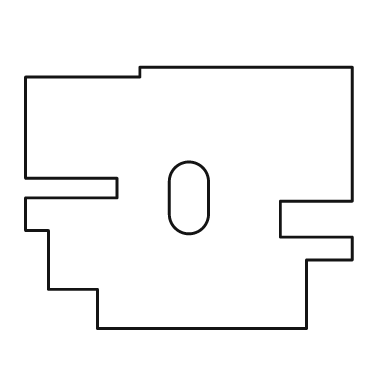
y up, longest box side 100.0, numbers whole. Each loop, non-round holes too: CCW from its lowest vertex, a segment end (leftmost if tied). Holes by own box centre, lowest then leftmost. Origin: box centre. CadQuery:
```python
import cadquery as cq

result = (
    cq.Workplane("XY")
    .moveTo(-28.0, -40.0)
    .lineTo(36.0, -40.0)
    .lineTo(36.0, -19.0)
    .lineTo(50.0, -19.0)
    .lineTo(50.0, -12.0)
    .lineTo(28.0, -12.0)
    .lineTo(28.0, -1.0)
    .lineTo(50.0, -1.0)
    .lineTo(50.0, 40.0)
    .lineTo(-15.0, 40.0)
    .lineTo(-15.0, 37.0)
    .lineTo(-50.0, 37.0)
    .lineTo(-50.0, 6.0)
    .lineTo(-22.0, 6.0)
    .lineTo(-22.0, 0.0)
    .lineTo(-50.0, 0.0)
    .lineTo(-50.0, -10.0)
    .lineTo(-43.0, -10.0)
    .lineTo(-43.0, -28.0)
    .lineTo(-28.0, -28.0)
    .close()
    .moveTo(-6.0, -5.0)
    .threePointArc((0.0, -11.0), (6.0, -5.0))
    .lineTo(6.0, 5.0)
    .threePointArc((0.0, 11.0), (-6.0, 5.0))
    .close()
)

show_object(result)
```